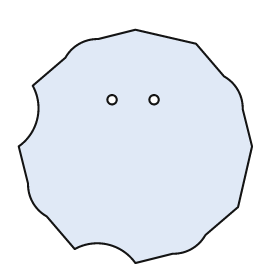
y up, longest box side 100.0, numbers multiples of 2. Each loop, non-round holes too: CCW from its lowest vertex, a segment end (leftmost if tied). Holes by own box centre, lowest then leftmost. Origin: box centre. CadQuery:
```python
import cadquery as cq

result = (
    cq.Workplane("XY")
    .moveTo(0.0, -50.0)
    .lineTo(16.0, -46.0)
    .threePointArc((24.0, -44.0), (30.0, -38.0))
    .lineTo(44.0, -26.0)
    .lineTo(50.0, 0.0)
    .lineTo(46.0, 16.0)
    .threePointArc((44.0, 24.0), (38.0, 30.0))
    .lineTo(26.0, 44.0)
    .lineTo(0.0, 50.0)
    .lineTo(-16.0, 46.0)
    .threePointArc((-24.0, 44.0), (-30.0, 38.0))
    .lineTo(-44.0, 26.0)
    .threePointArc((-42.0, 12.0), (-50.0, 0.0))
    .lineTo(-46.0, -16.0)
    .threePointArc((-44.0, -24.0), (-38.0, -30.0))
    .lineTo(-26.0, -44.0)
    .threePointArc((-12.0, -42.0), (0.0, -50.0))
    .close()
    .moveTo(-10.0, 20.0)
    .circle(2.0)
    .moveTo(8.0, 20.0)
    .circle(2.0)
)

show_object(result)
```